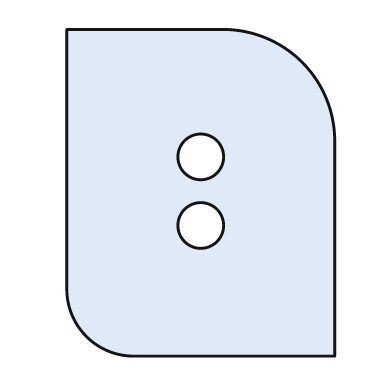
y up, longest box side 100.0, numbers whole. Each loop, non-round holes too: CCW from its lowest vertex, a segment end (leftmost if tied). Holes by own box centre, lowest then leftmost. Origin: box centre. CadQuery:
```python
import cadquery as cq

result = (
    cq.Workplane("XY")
    .moveTo(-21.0, -50.0)
    .lineTo(41.0, -50.0)
    .lineTo(41.0, 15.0)
    .threePointArc((31.0, 40.0), (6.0, 50.0))
    .lineTo(-41.0, 50.0)
    .lineTo(-41.0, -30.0)
    .threePointArc((-35.0, -44.0), (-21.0, -50.0))
    .close()
    .moveTo(0.0, -10.0)
    .circle(7.0)
    .moveTo(0.0, 11.0)
    .circle(7.0)
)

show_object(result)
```